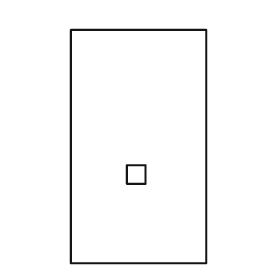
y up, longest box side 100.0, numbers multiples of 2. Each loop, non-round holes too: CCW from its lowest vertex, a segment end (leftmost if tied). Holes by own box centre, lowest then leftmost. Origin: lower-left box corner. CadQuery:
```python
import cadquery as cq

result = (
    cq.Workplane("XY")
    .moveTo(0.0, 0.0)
    .lineTo(58.0, 0.0)
    .lineTo(58.0, 100.0)
    .lineTo(0.0, 100.0)
    .close()
    .moveTo(24.0, 34.0)
    .lineTo(32.0, 34.0)
    .lineTo(32.0, 42.0)
    .lineTo(24.0, 42.0)
    .close()
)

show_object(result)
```